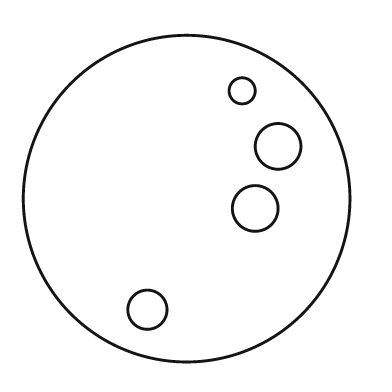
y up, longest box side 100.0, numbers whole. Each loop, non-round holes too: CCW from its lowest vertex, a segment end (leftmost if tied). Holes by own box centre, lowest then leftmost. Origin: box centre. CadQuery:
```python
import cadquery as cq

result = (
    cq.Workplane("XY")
    .moveTo(0.0, 0.0)
    .circle(50.0)
    .moveTo(-12.0, -34.0)
    .circle(6.0)
    .moveTo(21.0, -3.0)
    .circle(7.0)
    .moveTo(28.0, 16.0)
    .circle(7.0)
    .moveTo(17.0, 33.0)
    .circle(4.0)
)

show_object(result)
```